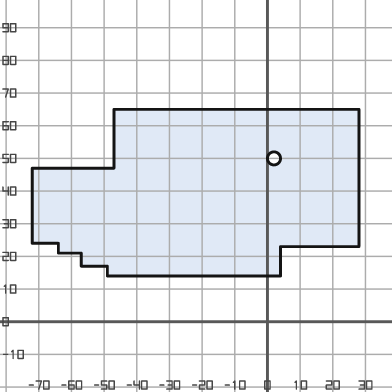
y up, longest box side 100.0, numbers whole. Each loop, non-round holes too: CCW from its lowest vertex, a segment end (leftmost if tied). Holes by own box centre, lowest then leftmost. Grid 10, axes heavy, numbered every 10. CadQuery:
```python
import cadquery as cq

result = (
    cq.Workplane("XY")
    .moveTo(-49.0, 14.0)
    .lineTo(4.0, 14.0)
    .lineTo(4.0, 23.0)
    .lineTo(28.0, 23.0)
    .lineTo(28.0, 65.0)
    .lineTo(-47.0, 65.0)
    .lineTo(-47.0, 47.0)
    .lineTo(-72.0, 47.0)
    .lineTo(-72.0, 24.0)
    .lineTo(-64.0, 24.0)
    .lineTo(-64.0, 21.0)
    .lineTo(-57.0, 21.0)
    .lineTo(-57.0, 17.0)
    .lineTo(-49.0, 17.0)
    .close()
    .moveTo(2.0, 50.0)
    .circle(2.0)
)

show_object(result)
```